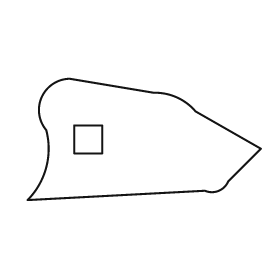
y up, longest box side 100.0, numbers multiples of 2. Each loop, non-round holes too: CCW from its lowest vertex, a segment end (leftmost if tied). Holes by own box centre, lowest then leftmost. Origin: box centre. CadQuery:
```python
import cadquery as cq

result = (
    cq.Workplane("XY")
    .moveTo(-50.0, -26.0)
    .lineTo(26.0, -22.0)
    .threePointArc((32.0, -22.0), (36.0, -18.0))
    .lineTo(50.0, -4.0)
    .lineTo(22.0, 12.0)
    .threePointArc((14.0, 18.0), (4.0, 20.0))
    .lineTo(-32.0, 26.0)
    .threePointArc((-44.0, 18.0), (-42.0, 4.0))
    .threePointArc((-42.0, -12.0), (-50.0, -26.0))
    .close()
    .moveTo(-30.0, -6.0)
    .lineTo(-18.0, -6.0)
    .lineTo(-18.0, 6.0)
    .lineTo(-30.0, 6.0)
    .close()
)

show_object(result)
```